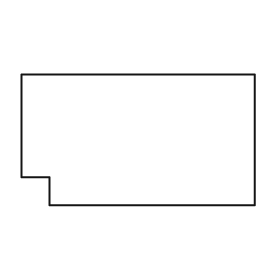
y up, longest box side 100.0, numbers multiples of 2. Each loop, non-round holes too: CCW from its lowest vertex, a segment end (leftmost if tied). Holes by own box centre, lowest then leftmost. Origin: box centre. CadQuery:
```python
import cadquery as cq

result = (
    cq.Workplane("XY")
    .moveTo(-38.0, -28.0)
    .lineTo(50.0, -28.0)
    .lineTo(50.0, 28.0)
    .lineTo(-50.0, 28.0)
    .lineTo(-50.0, -16.0)
    .lineTo(-38.0, -16.0)
    .close()
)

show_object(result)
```